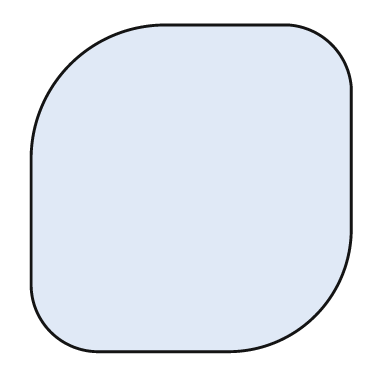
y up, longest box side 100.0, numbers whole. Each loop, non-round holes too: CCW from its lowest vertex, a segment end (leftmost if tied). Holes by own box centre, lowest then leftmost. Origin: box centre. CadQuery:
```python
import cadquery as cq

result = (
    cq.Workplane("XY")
    .moveTo(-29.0, -50.0)
    .lineTo(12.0, -50.0)
    .threePointArc((38.0, -39.0), (49.0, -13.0))
    .lineTo(49.0, 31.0)
    .threePointArc((43.0, 44.0), (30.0, 50.0))
    .lineTo(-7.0, 50.0)
    .threePointArc((-37.0, 38.0), (-49.0, 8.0))
    .lineTo(-49.0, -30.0)
    .threePointArc((-43.0, -44.0), (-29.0, -50.0))
    .close()
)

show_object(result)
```